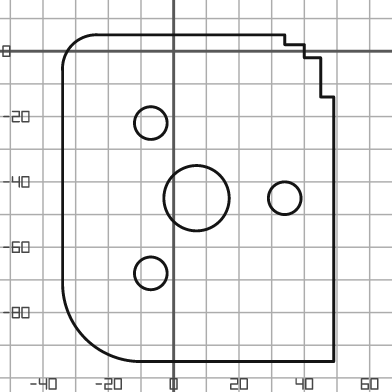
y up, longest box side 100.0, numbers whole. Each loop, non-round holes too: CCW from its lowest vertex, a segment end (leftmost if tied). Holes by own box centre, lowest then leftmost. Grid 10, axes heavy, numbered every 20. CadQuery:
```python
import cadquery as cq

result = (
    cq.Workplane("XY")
    .moveTo(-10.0, -95.0)
    .lineTo(49.0, -95.0)
    .lineTo(49.0, -14.0)
    .lineTo(45.0, -14.0)
    .lineTo(45.0, -2.0)
    .lineTo(40.0, -2.0)
    .lineTo(40.0, 2.0)
    .lineTo(34.0, 2.0)
    .lineTo(34.0, 5.0)
    .lineTo(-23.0, 5.0)
    .threePointArc((-31.0, 2.0), (-34.0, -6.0))
    .lineTo(-34.0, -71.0)
    .threePointArc((-27.0, -88.0), (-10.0, -95.0))
    .close()
    .moveTo(-7.0, -68.0)
    .circle(5.0)
    .moveTo(7.0, -45.0)
    .circle(10.0)
    .moveTo(34.0, -45.0)
    .circle(5.0)
    .moveTo(-7.0, -22.0)
    .circle(5.0)
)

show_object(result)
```